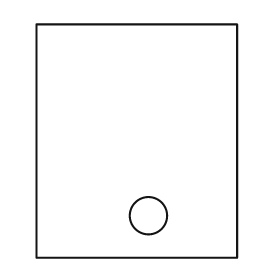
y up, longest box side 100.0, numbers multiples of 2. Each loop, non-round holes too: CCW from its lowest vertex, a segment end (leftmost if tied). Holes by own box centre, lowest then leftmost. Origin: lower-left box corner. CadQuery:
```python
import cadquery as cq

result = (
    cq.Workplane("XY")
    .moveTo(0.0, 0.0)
    .lineTo(86.0, 0.0)
    .lineTo(86.0, 100.0)
    .lineTo(0.0, 100.0)
    .close()
    .moveTo(48.0, 18.0)
    .circle(8.0)
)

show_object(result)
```